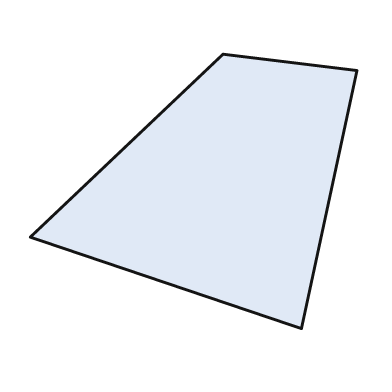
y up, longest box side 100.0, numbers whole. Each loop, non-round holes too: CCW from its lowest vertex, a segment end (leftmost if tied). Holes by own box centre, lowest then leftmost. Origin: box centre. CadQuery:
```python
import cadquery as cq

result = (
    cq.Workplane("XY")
    .moveTo(33.0, -42.0)
    .lineTo(50.0, 37.0)
    .lineTo(9.0, 42.0)
    .lineTo(-50.0, -14.0)
    .close()
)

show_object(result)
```